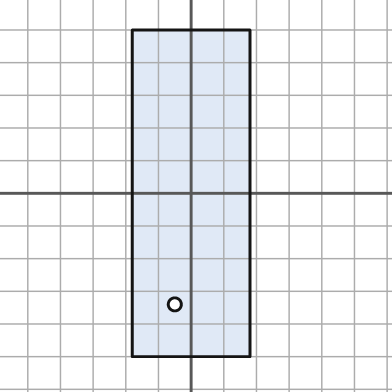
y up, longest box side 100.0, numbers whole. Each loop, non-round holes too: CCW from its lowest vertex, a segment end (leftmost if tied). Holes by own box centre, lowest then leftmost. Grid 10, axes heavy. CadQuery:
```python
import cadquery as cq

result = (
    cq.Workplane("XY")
    .moveTo(-18.0, -50.0)
    .lineTo(18.0, -50.0)
    .lineTo(18.0, 50.0)
    .lineTo(-18.0, 50.0)
    .close()
    .moveTo(-5.0, -34.0)
    .circle(2.0)
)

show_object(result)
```